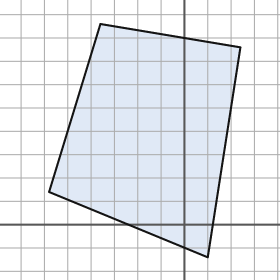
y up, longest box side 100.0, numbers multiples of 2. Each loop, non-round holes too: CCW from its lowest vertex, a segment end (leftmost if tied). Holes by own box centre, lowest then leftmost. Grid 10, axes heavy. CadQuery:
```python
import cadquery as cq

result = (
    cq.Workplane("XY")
    .moveTo(10.0, -14.0)
    .lineTo(24.0, 76.0)
    .lineTo(-36.0, 86.0)
    .lineTo(-58.0, 14.0)
    .close()
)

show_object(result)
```